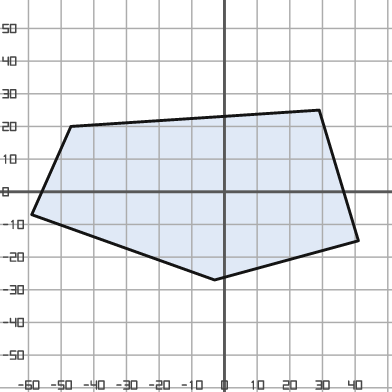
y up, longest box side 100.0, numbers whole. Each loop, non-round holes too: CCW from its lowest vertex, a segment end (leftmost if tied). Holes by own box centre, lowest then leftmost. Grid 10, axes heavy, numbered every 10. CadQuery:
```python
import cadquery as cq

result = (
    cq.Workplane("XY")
    .moveTo(-3.0, -27.0)
    .lineTo(41.0, -15.0)
    .lineTo(29.0, 25.0)
    .lineTo(-47.0, 20.0)
    .lineTo(-59.0, -7.0)
    .close()
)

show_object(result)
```